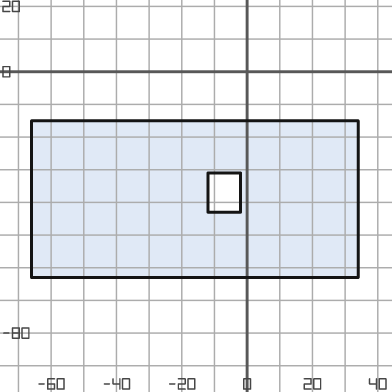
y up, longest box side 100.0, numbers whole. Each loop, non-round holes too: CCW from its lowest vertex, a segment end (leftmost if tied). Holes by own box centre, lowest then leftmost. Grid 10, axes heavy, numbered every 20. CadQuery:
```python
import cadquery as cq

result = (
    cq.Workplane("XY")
    .moveTo(-66.0, -63.0)
    .lineTo(34.0, -63.0)
    .lineTo(34.0, -15.0)
    .lineTo(-66.0, -15.0)
    .close()
    .moveTo(-12.0, -43.0)
    .lineTo(-2.0, -43.0)
    .lineTo(-2.0, -31.0)
    .lineTo(-12.0, -31.0)
    .close()
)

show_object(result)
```